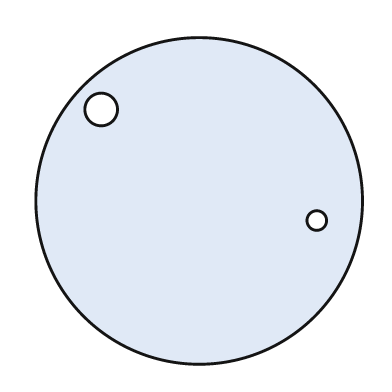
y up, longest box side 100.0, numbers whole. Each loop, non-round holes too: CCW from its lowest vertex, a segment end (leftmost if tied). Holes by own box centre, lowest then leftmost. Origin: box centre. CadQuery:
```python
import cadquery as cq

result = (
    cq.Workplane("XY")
    .moveTo(0.0, 0.0)
    .circle(50.0)
    .moveTo(36.0, -6.0)
    .circle(3.0)
    .moveTo(-30.0, 28.0)
    .circle(5.0)
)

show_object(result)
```